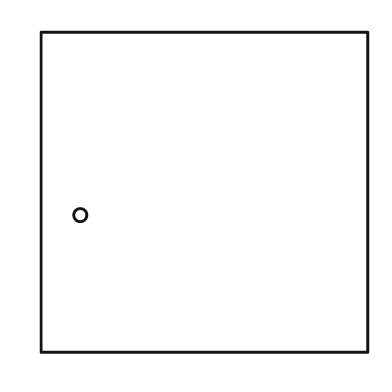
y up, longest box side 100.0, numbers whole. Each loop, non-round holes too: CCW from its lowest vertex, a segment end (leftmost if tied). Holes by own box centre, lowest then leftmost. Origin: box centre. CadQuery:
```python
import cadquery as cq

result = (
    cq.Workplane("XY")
    .moveTo(-50.0, -49.0)
    .lineTo(50.0, -49.0)
    .lineTo(50.0, 49.0)
    .lineTo(-50.0, 49.0)
    .close()
    .moveTo(-38.0, -7.0)
    .circle(2.0)
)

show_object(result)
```